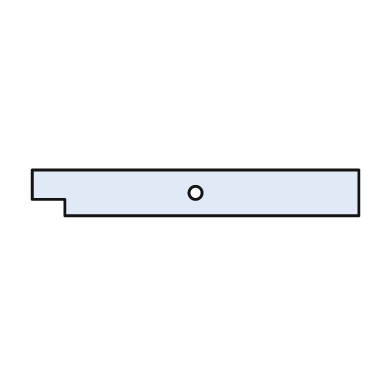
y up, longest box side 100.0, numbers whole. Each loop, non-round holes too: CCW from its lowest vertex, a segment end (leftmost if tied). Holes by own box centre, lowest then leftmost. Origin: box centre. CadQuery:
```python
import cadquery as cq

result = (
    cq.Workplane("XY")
    .moveTo(-40.0, -7.0)
    .lineTo(50.0, -7.0)
    .lineTo(50.0, 7.0)
    .lineTo(-50.0, 7.0)
    .lineTo(-50.0, -2.0)
    .lineTo(-40.0, -2.0)
    .close()
    .moveTo(0.0, 0.0)
    .circle(2.0)
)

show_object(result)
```